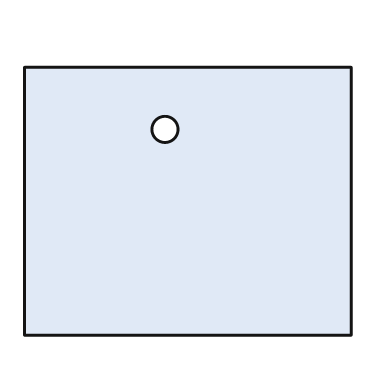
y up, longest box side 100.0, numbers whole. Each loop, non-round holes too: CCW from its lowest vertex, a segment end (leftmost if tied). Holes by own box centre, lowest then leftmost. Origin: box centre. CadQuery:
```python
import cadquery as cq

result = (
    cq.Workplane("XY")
    .moveTo(-50.0, -41.0)
    .lineTo(50.0, -41.0)
    .lineTo(50.0, 41.0)
    .lineTo(-50.0, 41.0)
    .close()
    .moveTo(-7.0, 22.0)
    .circle(4.0)
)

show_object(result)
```